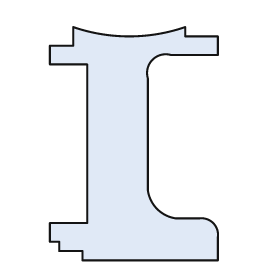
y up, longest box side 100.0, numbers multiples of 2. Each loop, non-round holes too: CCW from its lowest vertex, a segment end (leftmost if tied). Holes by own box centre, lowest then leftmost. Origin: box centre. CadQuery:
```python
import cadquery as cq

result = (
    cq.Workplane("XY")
    .moveTo(-22.0, -50.0)
    .lineTo(36.0, -50.0)
    .lineTo(36.0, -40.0)
    .threePointArc((34.0, -34.0), (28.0, -32.0))
    .lineTo(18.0, -32.0)
    .threePointArc((10.0, -28.0), (6.0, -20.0))
    .lineTo(6.0, 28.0)
    .threePointArc((8.0, 36.0), (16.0, 38.0))
    .lineTo(36.0, 38.0)
    .lineTo(36.0, 46.0)
    .lineTo(22.0, 46.0)
    .lineTo(22.0, 50.0)
    .threePointArc((-2.0, 46.0), (-26.0, 50.0))
    .lineTo(-26.0, 42.0)
    .lineTo(-36.0, 42.0)
    .lineTo(-36.0, 34.0)
    .lineTo(-20.0, 34.0)
    .lineTo(-20.0, -34.0)
    .lineTo(-36.0, -34.0)
    .lineTo(-36.0, -42.0)
    .lineTo(-32.0, -42.0)
    .lineTo(-32.0, -46.0)
    .lineTo(-22.0, -46.0)
    .close()
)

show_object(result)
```